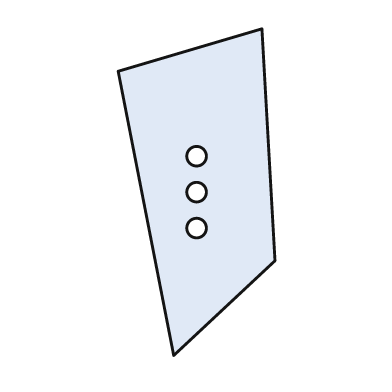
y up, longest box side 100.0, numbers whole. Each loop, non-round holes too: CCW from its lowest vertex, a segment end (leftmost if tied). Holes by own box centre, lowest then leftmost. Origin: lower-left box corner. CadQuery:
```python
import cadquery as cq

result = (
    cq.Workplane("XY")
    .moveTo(17.0, 0.0)
    .lineTo(48.0, 29.0)
    .lineTo(44.0, 100.0)
    .lineTo(0.0, 87.0)
    .close()
    .moveTo(24.0, 39.0)
    .circle(3.0)
    .moveTo(24.0, 50.0)
    .circle(3.0)
    .moveTo(24.0, 61.0)
    .circle(3.0)
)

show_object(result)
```